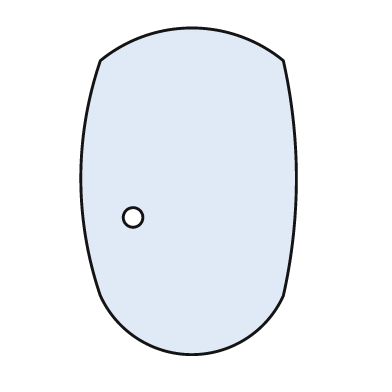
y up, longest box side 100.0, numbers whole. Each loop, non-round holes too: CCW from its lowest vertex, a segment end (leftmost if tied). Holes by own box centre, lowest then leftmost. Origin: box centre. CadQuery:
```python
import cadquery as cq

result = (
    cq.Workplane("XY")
    .moveTo(-27.0, -32.0)
    .threePointArc((1.0, -50.0), (29.0, -32.0))
    .threePointArc((33.0, 4.0), (29.0, 40.0))
    .threePointArc((1.0, 50.0), (-27.0, 40.0))
    .threePointArc((-33.0, 4.0), (-27.0, -32.0))
    .close()
    .moveTo(-17.0, -8.0)
    .circle(3.0)
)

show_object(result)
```